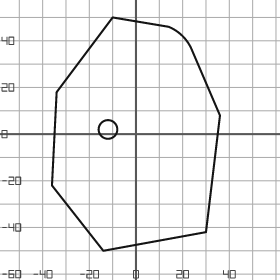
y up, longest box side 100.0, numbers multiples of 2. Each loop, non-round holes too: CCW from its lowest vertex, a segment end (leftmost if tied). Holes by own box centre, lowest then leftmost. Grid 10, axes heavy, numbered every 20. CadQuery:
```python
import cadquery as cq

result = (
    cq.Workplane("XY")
    .moveTo(-14.0, -50.0)
    .lineTo(30.0, -42.0)
    .lineTo(36.0, 8.0)
    .lineTo(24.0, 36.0)
    .threePointArc((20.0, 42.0), (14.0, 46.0))
    .lineTo(-10.0, 50.0)
    .lineTo(-34.0, 18.0)
    .lineTo(-36.0, -22.0)
    .close()
    .moveTo(-12.0, 2.0)
    .circle(4.0)
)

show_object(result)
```